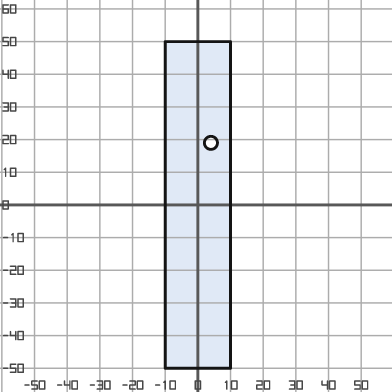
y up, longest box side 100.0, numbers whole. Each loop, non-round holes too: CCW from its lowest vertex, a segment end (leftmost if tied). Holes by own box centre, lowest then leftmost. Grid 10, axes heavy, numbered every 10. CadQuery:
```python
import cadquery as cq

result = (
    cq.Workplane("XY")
    .moveTo(-10.0, -50.0)
    .lineTo(10.0, -50.0)
    .lineTo(10.0, 50.0)
    .lineTo(-10.0, 50.0)
    .close()
    .moveTo(4.0, 19.0)
    .circle(2.0)
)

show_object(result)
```